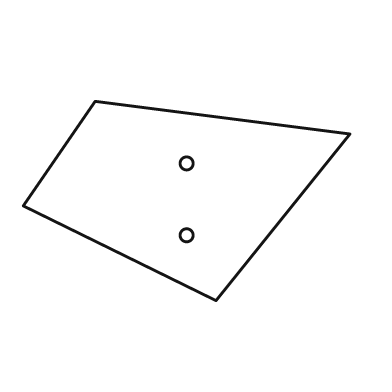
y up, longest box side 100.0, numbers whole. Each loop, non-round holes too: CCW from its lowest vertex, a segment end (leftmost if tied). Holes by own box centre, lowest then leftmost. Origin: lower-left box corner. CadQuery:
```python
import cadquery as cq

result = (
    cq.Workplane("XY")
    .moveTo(59.0, 0.0)
    .lineTo(100.0, 51.0)
    .lineTo(22.0, 61.0)
    .lineTo(0.0, 29.0)
    .close()
    .moveTo(50.0, 20.0)
    .circle(2.0)
    .moveTo(50.0, 42.0)
    .circle(2.0)
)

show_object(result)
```